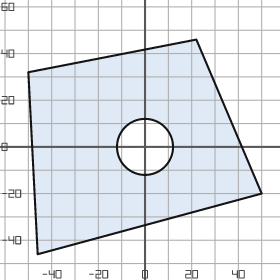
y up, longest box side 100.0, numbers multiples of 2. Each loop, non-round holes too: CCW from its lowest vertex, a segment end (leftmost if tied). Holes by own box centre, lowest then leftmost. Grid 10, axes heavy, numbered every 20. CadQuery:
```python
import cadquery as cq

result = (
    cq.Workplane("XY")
    .moveTo(-46.0, -46.0)
    .lineTo(50.0, -20.0)
    .lineTo(22.0, 46.0)
    .lineTo(-50.0, 32.0)
    .close()
    .moveTo(0.0, 0.0)
    .circle(12.0)
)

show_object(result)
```